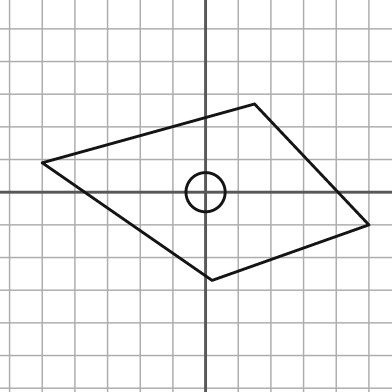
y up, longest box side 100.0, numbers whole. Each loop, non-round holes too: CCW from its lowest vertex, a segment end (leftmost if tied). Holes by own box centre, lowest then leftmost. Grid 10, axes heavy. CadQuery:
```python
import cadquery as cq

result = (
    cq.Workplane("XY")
    .moveTo(2.0, -27.0)
    .lineTo(50.0, -10.0)
    .lineTo(15.0, 27.0)
    .lineTo(-50.0, 9.0)
    .close()
    .moveTo(0.0, 0.0)
    .circle(6.0)
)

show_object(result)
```